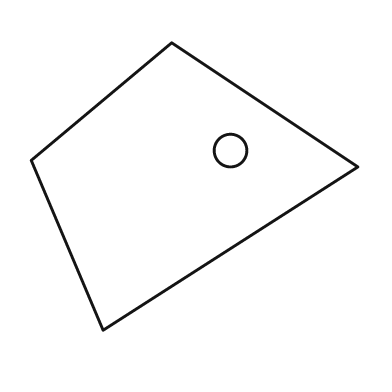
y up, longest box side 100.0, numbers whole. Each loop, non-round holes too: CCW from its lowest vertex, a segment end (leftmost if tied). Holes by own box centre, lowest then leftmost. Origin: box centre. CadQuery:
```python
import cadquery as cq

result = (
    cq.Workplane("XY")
    .moveTo(-28.0, -44.0)
    .lineTo(50.0, 6.0)
    .lineTo(-7.0, 44.0)
    .lineTo(-50.0, 8.0)
    .close()
    .moveTo(11.0, 11.0)
    .circle(5.0)
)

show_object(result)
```